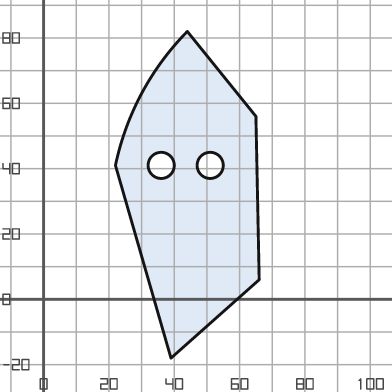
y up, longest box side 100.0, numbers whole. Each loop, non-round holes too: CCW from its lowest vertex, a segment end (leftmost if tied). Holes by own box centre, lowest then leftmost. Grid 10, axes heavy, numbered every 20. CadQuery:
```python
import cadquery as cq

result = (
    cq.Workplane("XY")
    .moveTo(39.0, -18.0)
    .lineTo(66.0, 6.0)
    .lineTo(65.0, 56.0)
    .lineTo(44.0, 82.0)
    .threePointArc((30.0, 63.0), (22.0, 41.0))
    .close()
    .moveTo(36.0, 41.0)
    .circle(4.0)
    .moveTo(51.0, 41.0)
    .circle(4.0)
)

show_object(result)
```